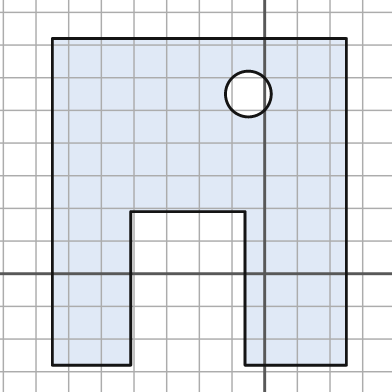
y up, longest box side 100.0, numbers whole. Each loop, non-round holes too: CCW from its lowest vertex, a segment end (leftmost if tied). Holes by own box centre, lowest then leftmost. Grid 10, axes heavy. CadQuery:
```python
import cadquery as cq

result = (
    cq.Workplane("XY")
    .moveTo(-65.0, -28.0)
    .lineTo(-41.0, -28.0)
    .lineTo(-41.0, 19.0)
    .lineTo(-6.0, 19.0)
    .lineTo(-6.0, -28.0)
    .lineTo(25.0, -28.0)
    .lineTo(25.0, 72.0)
    .lineTo(-65.0, 72.0)
    .close()
    .moveTo(-5.0, 55.0)
    .circle(7.0)
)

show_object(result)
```